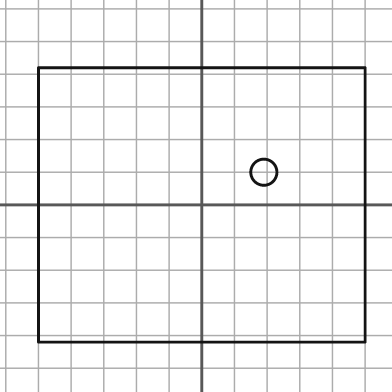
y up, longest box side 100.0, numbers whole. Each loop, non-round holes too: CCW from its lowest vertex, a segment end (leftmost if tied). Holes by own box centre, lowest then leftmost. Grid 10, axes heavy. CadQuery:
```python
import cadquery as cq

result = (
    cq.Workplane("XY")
    .moveTo(-50.0, -42.0)
    .lineTo(50.0, -42.0)
    .lineTo(50.0, 42.0)
    .lineTo(-50.0, 42.0)
    .close()
    .moveTo(19.0, 10.0)
    .circle(4.0)
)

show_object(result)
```